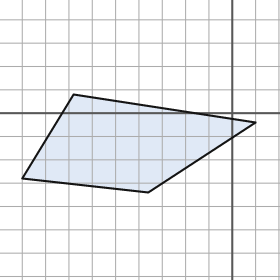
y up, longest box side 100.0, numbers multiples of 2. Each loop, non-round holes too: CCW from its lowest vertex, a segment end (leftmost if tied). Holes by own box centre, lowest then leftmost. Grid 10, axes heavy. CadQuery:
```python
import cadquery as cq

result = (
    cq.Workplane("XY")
    .moveTo(-36.0, -34.0)
    .lineTo(10.0, -4.0)
    .lineTo(-68.0, 8.0)
    .lineTo(-90.0, -28.0)
    .close()
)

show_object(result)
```